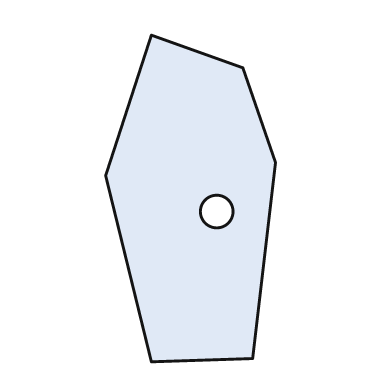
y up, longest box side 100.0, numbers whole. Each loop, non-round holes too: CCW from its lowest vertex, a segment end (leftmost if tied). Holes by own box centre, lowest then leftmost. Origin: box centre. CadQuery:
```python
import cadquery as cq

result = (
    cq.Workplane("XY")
    .moveTo(-12.0, -50.0)
    .lineTo(19.0, -49.0)
    .lineTo(26.0, 11.0)
    .lineTo(16.0, 40.0)
    .lineTo(-12.0, 50.0)
    .lineTo(-26.0, 7.0)
    .close()
    .moveTo(8.0, -4.0)
    .circle(5.0)
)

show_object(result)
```